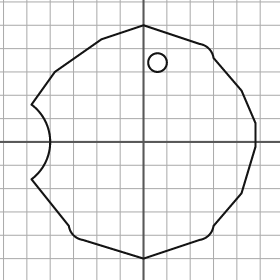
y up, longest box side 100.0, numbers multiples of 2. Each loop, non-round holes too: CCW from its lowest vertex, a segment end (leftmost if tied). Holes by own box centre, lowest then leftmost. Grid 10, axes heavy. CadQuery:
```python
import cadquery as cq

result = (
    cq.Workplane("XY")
    .moveTo(0.0, -50.0)
    .lineTo(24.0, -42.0)
    .threePointArc((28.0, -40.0), (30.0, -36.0))
    .lineTo(42.0, -22.0)
    .lineTo(48.0, -2.0)
    .lineTo(48.0, 8.0)
    .lineTo(42.0, 22.0)
    .lineTo(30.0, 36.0)
    .threePointArc((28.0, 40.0), (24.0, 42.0))
    .lineTo(0.0, 50.0)
    .lineTo(-18.0, 44.0)
    .lineTo(-38.0, 30.0)
    .lineTo(-48.0, 16.0)
    .threePointArc((-40.0, 0.0), (-48.0, -16.0))
    .lineTo(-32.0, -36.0)
    .threePointArc((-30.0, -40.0), (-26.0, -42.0))
    .close()
    .moveTo(6.0, 34.0)
    .circle(4.0)
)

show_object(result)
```